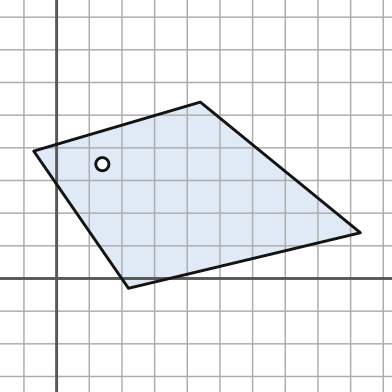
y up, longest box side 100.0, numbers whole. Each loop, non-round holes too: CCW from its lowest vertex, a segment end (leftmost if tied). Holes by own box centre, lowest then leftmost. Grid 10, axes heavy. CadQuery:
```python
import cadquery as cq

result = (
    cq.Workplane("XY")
    .moveTo(22.0, -3.0)
    .lineTo(93.0, 14.0)
    .lineTo(44.0, 54.0)
    .lineTo(-7.0, 39.0)
    .close()
    .moveTo(14.0, 35.0)
    .circle(2.0)
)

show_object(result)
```